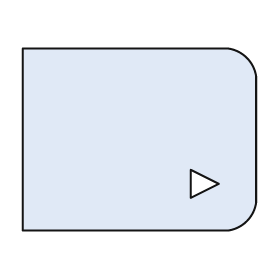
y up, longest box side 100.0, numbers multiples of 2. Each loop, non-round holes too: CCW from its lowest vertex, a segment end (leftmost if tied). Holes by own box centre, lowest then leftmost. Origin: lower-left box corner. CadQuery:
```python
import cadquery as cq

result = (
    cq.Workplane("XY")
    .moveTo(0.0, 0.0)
    .lineTo(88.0, 0.0)
    .threePointArc((96.0, 4.0), (100.0, 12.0))
    .lineTo(100.0, 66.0)
    .threePointArc((96.0, 74.0), (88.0, 78.0))
    .lineTo(0.0, 78.0)
    .close()
    .moveTo(72.0, 14.0)
    .lineTo(84.0, 20.0)
    .lineTo(72.0, 26.0)
    .close()
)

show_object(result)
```